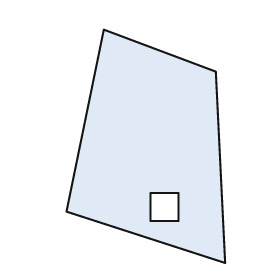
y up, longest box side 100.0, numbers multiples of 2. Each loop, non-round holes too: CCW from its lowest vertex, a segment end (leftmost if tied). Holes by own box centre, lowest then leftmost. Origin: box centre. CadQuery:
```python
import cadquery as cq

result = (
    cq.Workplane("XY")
    .moveTo(34.0, -50.0)
    .lineTo(30.0, 32.0)
    .lineTo(-18.0, 50.0)
    .lineTo(-34.0, -28.0)
    .close()
    .moveTo(2.0, -32.0)
    .lineTo(14.0, -32.0)
    .lineTo(14.0, -20.0)
    .lineTo(2.0, -20.0)
    .close()
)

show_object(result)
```